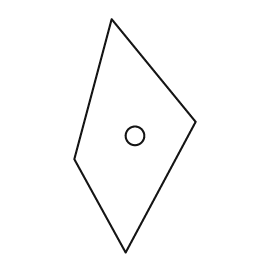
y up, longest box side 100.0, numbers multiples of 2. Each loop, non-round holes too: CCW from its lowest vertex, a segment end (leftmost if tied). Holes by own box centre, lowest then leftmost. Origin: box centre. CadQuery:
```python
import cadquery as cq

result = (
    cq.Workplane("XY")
    .moveTo(-4.0, -50.0)
    .lineTo(26.0, 6.0)
    .lineTo(-10.0, 50.0)
    .lineTo(-26.0, -10.0)
    .close()
    .moveTo(0.0, 0.0)
    .circle(4.0)
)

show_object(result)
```